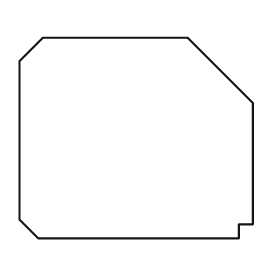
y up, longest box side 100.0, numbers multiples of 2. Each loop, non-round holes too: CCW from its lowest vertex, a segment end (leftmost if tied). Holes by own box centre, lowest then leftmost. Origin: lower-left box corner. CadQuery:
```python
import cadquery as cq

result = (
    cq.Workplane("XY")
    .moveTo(8.0, 0.0)
    .lineTo(94.0, 0.0)
    .lineTo(94.0, 6.0)
    .lineTo(100.0, 6.0)
    .lineTo(100.0, 58.0)
    .lineTo(72.0, 86.0)
    .lineTo(10.0, 86.0)
    .lineTo(0.0, 76.0)
    .lineTo(0.0, 8.0)
    .close()
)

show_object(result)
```